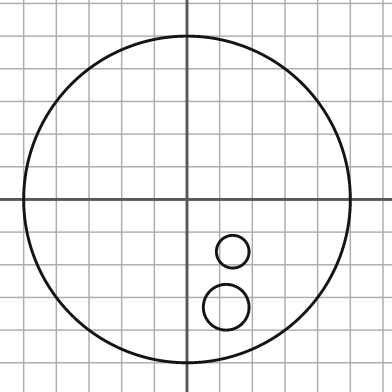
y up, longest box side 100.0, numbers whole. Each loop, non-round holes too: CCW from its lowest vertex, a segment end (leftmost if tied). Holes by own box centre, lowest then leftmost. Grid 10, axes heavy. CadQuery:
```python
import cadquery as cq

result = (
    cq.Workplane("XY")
    .moveTo(0.0, 0.0)
    .circle(50.0)
    .moveTo(12.0, -33.0)
    .circle(7.0)
    .moveTo(14.0, -16.0)
    .circle(5.0)
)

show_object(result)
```